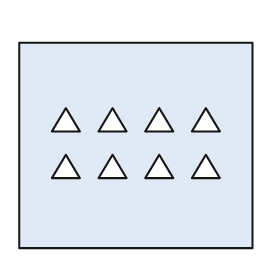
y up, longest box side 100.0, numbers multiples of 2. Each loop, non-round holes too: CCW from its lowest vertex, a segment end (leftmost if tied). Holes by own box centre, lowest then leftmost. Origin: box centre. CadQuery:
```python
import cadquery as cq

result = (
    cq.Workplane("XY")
    .moveTo(-50.0, -44.0)
    .lineTo(50.0, -44.0)
    .lineTo(50.0, 44.0)
    .lineTo(-50.0, 44.0)
    .close()
    .moveTo(-36.0, -14.0)
    .lineTo(-24.0, -14.0)
    .lineTo(-30.0, -4.0)
    .close()
    .moveTo(-16.0, -14.0)
    .lineTo(-4.0, -14.0)
    .lineTo(-10.0, -4.0)
    .close()
    .moveTo(4.0, -14.0)
    .lineTo(16.0, -14.0)
    .lineTo(10.0, -4.0)
    .close()
    .moveTo(24.0, -14.0)
    .lineTo(36.0, -14.0)
    .lineTo(30.0, -4.0)
    .close()
    .moveTo(-36.0, 6.0)
    .lineTo(-24.0, 6.0)
    .lineTo(-30.0, 16.0)
    .close()
    .moveTo(-16.0, 6.0)
    .lineTo(-4.0, 6.0)
    .lineTo(-10.0, 16.0)
    .close()
    .moveTo(4.0, 6.0)
    .lineTo(16.0, 6.0)
    .lineTo(10.0, 16.0)
    .close()
    .moveTo(24.0, 6.0)
    .lineTo(36.0, 6.0)
    .lineTo(30.0, 16.0)
    .close()
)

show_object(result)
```